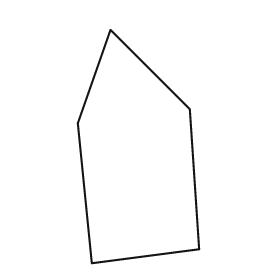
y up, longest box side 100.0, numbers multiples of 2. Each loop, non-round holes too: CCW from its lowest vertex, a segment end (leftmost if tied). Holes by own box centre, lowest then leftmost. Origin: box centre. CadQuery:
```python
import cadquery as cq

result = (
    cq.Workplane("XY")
    .moveTo(-20.0, -50.0)
    .lineTo(26.0, -44.0)
    .lineTo(22.0, 16.0)
    .lineTo(-12.0, 50.0)
    .lineTo(-26.0, 10.0)
    .close()
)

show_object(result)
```